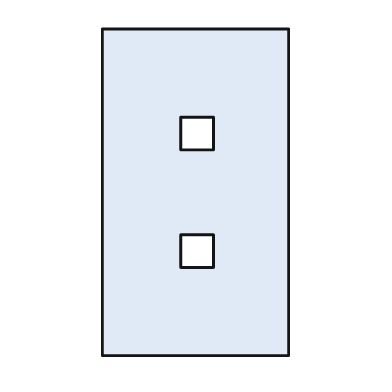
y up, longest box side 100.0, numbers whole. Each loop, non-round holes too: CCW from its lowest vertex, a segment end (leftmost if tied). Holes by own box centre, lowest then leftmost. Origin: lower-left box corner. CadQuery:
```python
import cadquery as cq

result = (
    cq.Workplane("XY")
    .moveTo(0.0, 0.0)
    .lineTo(57.0, 0.0)
    .lineTo(57.0, 100.0)
    .lineTo(0.0, 100.0)
    .close()
    .moveTo(24.0, 27.0)
    .lineTo(34.0, 27.0)
    .lineTo(34.0, 37.0)
    .lineTo(24.0, 37.0)
    .close()
    .moveTo(24.0, 63.0)
    .lineTo(34.0, 63.0)
    .lineTo(34.0, 73.0)
    .lineTo(24.0, 73.0)
    .close()
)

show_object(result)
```